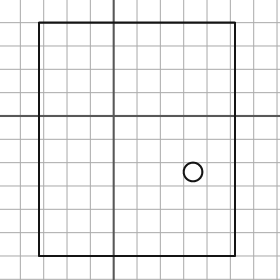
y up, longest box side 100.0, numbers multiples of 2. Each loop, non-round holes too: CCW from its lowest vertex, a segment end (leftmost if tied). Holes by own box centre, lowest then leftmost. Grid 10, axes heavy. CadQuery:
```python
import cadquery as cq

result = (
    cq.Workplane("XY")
    .moveTo(-32.0, -60.0)
    .lineTo(52.0, -60.0)
    .lineTo(52.0, 40.0)
    .lineTo(-32.0, 40.0)
    .close()
    .moveTo(34.0, -24.0)
    .circle(4.0)
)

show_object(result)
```